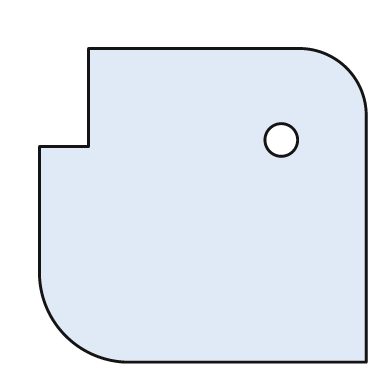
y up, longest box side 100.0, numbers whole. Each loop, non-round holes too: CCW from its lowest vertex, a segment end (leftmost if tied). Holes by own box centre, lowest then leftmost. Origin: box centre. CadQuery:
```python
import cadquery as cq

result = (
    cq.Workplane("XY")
    .moveTo(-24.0, -48.0)
    .lineTo(50.0, -48.0)
    .lineTo(50.0, 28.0)
    .threePointArc((44.0, 42.0), (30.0, 48.0))
    .lineTo(-35.0, 48.0)
    .lineTo(-35.0, 18.0)
    .lineTo(-50.0, 18.0)
    .lineTo(-50.0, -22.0)
    .threePointArc((-42.0, -40.0), (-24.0, -48.0))
    .close()
    .moveTo(24.0, 20.0)
    .circle(5.0)
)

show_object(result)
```